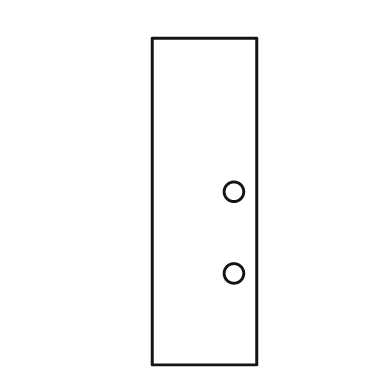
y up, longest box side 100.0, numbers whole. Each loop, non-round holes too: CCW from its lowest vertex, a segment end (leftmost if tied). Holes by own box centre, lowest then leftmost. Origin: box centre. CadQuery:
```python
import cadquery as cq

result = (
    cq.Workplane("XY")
    .moveTo(-16.0, -50.0)
    .lineTo(16.0, -50.0)
    .lineTo(16.0, 50.0)
    .lineTo(-16.0, 50.0)
    .close()
    .moveTo(9.0, -22.0)
    .circle(3.0)
    .moveTo(9.0, 3.0)
    .circle(3.0)
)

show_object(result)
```